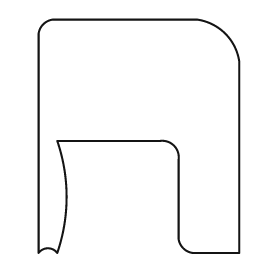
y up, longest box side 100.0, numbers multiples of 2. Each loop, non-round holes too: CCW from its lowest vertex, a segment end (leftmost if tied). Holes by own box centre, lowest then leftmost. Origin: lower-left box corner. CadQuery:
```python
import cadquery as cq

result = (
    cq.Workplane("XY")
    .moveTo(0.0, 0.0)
    .threePointArc((4.0, 2.0), (8.0, 0.0))
    .threePointArc((12.0, 24.0), (8.0, 48.0))
    .lineTo(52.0, 48.0)
    .threePointArc((58.0, 46.0), (60.0, 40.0))
    .lineTo(60.0, 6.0)
    .threePointArc((62.0, 2.0), (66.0, 0.0))
    .lineTo(86.0, 0.0)
    .lineTo(86.0, 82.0)
    .threePointArc((80.0, 94.0), (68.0, 100.0))
    .lineTo(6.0, 100.0)
    .threePointArc((2.0, 98.0), (0.0, 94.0))
    .close()
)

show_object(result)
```